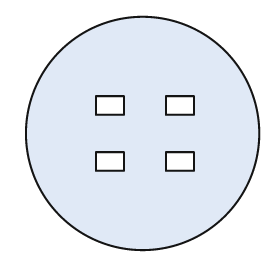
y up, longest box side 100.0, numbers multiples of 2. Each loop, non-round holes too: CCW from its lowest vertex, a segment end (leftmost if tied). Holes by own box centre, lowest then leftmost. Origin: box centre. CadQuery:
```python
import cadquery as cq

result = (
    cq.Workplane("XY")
    .moveTo(0.0, 0.0)
    .circle(50.0)
    .moveTo(-20.0, -16.0)
    .lineTo(-8.0, -16.0)
    .lineTo(-8.0, -8.0)
    .lineTo(-20.0, -8.0)
    .close()
    .moveTo(10.0, -16.0)
    .lineTo(22.0, -16.0)
    .lineTo(22.0, -8.0)
    .lineTo(10.0, -8.0)
    .close()
    .moveTo(-20.0, 8.0)
    .lineTo(-8.0, 8.0)
    .lineTo(-8.0, 16.0)
    .lineTo(-20.0, 16.0)
    .close()
    .moveTo(10.0, 8.0)
    .lineTo(22.0, 8.0)
    .lineTo(22.0, 16.0)
    .lineTo(10.0, 16.0)
    .close()
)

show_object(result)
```